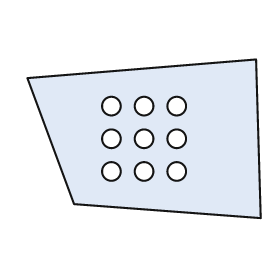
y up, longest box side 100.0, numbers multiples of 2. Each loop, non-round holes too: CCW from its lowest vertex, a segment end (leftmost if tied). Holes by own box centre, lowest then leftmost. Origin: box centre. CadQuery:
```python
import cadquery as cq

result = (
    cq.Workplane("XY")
    .moveTo(50.0, -34.0)
    .lineTo(48.0, 34.0)
    .lineTo(-50.0, 26.0)
    .lineTo(-30.0, -28.0)
    .close()
    .moveTo(-14.0, -14.0)
    .circle(4.0)
    .moveTo(0.0, -14.0)
    .circle(4.0)
    .moveTo(14.0, -14.0)
    .circle(4.0)
    .moveTo(-14.0, 0.0)
    .circle(4.0)
    .moveTo(0.0, 0.0)
    .circle(4.0)
    .moveTo(14.0, 0.0)
    .circle(4.0)
    .moveTo(-14.0, 14.0)
    .circle(4.0)
    .moveTo(0.0, 14.0)
    .circle(4.0)
    .moveTo(14.0, 14.0)
    .circle(4.0)
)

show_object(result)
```